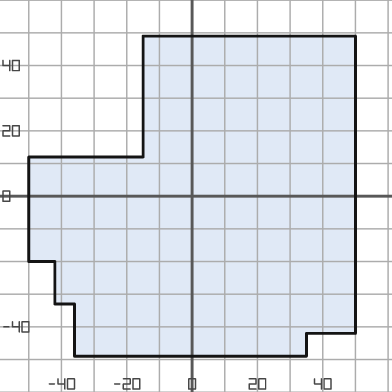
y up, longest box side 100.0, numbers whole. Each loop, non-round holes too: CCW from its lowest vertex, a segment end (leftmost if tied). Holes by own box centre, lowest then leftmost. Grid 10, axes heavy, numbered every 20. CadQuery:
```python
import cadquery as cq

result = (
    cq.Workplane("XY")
    .moveTo(-36.0, -49.0)
    .lineTo(35.0, -49.0)
    .lineTo(35.0, -42.0)
    .lineTo(50.0, -42.0)
    .lineTo(50.0, 49.0)
    .lineTo(-15.0, 49.0)
    .lineTo(-15.0, 12.0)
    .lineTo(-50.0, 12.0)
    .lineTo(-50.0, -20.0)
    .lineTo(-42.0, -20.0)
    .lineTo(-42.0, -33.0)
    .lineTo(-36.0, -33.0)
    .close()
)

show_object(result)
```